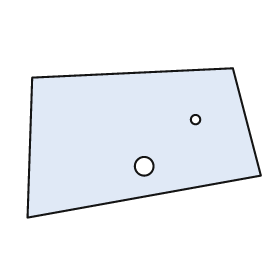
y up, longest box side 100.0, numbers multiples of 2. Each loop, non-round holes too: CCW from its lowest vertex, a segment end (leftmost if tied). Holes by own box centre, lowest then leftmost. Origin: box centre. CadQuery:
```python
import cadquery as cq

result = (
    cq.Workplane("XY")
    .moveTo(-50.0, -32.0)
    .lineTo(50.0, -14.0)
    .lineTo(38.0, 32.0)
    .lineTo(-48.0, 28.0)
    .close()
    .moveTo(0.0, -10.0)
    .circle(4.0)
    .moveTo(22.0, 10.0)
    .circle(2.0)
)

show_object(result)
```